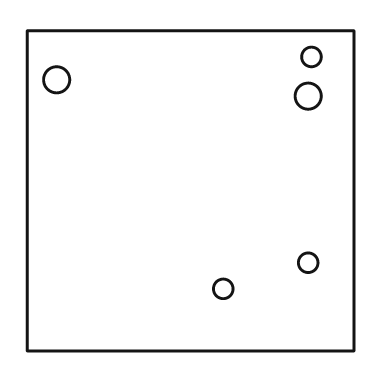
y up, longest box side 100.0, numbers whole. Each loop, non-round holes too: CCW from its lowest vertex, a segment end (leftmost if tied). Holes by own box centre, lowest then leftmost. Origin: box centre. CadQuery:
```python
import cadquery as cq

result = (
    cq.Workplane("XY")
    .moveTo(-50.0, -49.0)
    .lineTo(50.0, -49.0)
    .lineTo(50.0, 49.0)
    .lineTo(-50.0, 49.0)
    .close()
    .moveTo(10.0, -30.0)
    .circle(3.0)
    .moveTo(36.0, -22.0)
    .circle(3.0)
    .moveTo(36.0, 29.0)
    .circle(4.0)
    .moveTo(-41.0, 34.0)
    .circle(4.0)
    .moveTo(37.0, 41.0)
    .circle(3.0)
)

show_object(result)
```